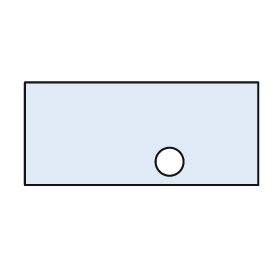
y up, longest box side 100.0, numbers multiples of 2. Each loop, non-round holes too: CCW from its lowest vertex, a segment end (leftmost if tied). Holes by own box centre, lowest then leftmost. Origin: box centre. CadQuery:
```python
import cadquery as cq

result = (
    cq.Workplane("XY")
    .moveTo(-50.0, -22.0)
    .lineTo(50.0, -22.0)
    .lineTo(50.0, 22.0)
    .lineTo(-50.0, 22.0)
    .close()
    .moveTo(12.0, -12.0)
    .circle(6.0)
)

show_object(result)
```